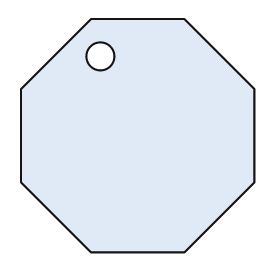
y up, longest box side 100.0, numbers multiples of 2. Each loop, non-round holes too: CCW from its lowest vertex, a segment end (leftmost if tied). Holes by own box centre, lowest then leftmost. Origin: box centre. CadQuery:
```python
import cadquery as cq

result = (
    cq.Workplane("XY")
    .moveTo(-20.0, -50.0)
    .lineTo(20.0, -50.0)
    .lineTo(50.0, -20.0)
    .lineTo(50.0, 20.0)
    .lineTo(20.0, 50.0)
    .lineTo(-20.0, 50.0)
    .lineTo(-50.0, 20.0)
    .lineTo(-50.0, -20.0)
    .close()
    .moveTo(-16.0, 34.0)
    .circle(6.0)
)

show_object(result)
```